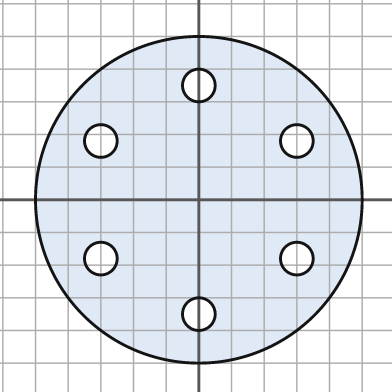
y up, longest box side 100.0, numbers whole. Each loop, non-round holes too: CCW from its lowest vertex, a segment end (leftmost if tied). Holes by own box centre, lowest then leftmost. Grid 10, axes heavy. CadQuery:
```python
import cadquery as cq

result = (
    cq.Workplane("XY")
    .moveTo(0.0, 0.0)
    .circle(50.0)
    .moveTo(0.0, -35.0)
    .circle(5.0)
    .moveTo(-30.0, -18.0)
    .circle(5.0)
    .moveTo(30.0, -18.0)
    .circle(5.0)
    .moveTo(-30.0, 18.0)
    .circle(5.0)
    .moveTo(30.0, 18.0)
    .circle(5.0)
    .moveTo(0.0, 35.0)
    .circle(5.0)
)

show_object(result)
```